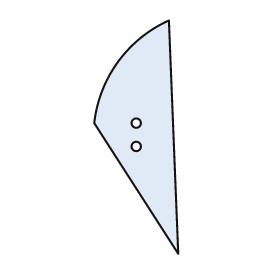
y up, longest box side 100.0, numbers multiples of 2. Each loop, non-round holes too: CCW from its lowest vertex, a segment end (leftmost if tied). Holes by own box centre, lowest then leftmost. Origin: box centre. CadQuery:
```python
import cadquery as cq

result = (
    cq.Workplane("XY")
    .moveTo(18.0, -50.0)
    .lineTo(14.0, 50.0)
    .threePointArc((-8.0, 32.0), (-18.0, 6.0))
    .close()
    .moveTo(0.0, -4.0)
    .circle(2.0)
    .moveTo(0.0, 6.0)
    .circle(2.0)
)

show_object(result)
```